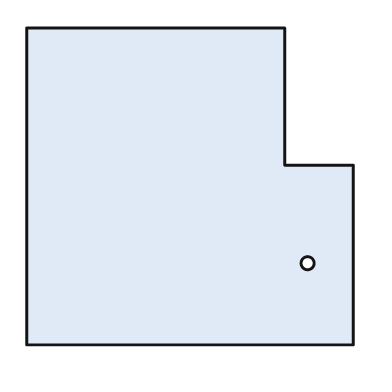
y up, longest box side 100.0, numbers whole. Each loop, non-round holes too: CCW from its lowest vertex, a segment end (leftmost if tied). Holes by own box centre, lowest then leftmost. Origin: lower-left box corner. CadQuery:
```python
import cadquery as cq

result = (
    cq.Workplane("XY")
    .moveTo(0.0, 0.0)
    .lineTo(100.0, 0.0)
    .lineTo(100.0, 55.0)
    .lineTo(79.0, 55.0)
    .lineTo(79.0, 97.0)
    .lineTo(0.0, 97.0)
    .close()
    .moveTo(86.0, 25.0)
    .circle(2.0)
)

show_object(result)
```